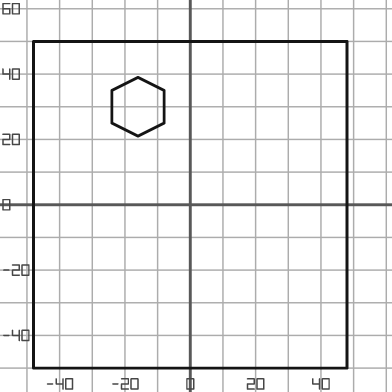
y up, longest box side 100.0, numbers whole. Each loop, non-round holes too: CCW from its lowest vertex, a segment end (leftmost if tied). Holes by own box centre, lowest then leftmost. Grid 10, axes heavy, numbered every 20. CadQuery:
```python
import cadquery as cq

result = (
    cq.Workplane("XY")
    .moveTo(-48.0, -50.0)
    .lineTo(48.0, -50.0)
    .lineTo(48.0, 50.0)
    .lineTo(-48.0, 50.0)
    .close()
    .moveTo(-16.0, 21.0)
    .lineTo(-8.0, 25.0)
    .lineTo(-8.0, 35.0)
    .lineTo(-16.0, 39.0)
    .lineTo(-24.0, 35.0)
    .lineTo(-24.0, 25.0)
    .close()
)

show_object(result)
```